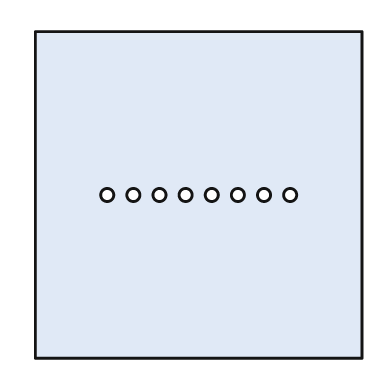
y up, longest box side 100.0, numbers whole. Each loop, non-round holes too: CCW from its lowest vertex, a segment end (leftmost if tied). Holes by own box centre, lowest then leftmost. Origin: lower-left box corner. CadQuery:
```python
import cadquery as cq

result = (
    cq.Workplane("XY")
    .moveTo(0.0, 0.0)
    .lineTo(100.0, 0.0)
    .lineTo(100.0, 100.0)
    .lineTo(0.0, 100.0)
    .close()
    .moveTo(22.0, 50.0)
    .circle(2.0)
    .moveTo(30.0, 50.0)
    .circle(2.0)
    .moveTo(38.0, 50.0)
    .circle(2.0)
    .moveTo(46.0, 50.0)
    .circle(2.0)
    .moveTo(54.0, 50.0)
    .circle(2.0)
    .moveTo(62.0, 50.0)
    .circle(2.0)
    .moveTo(70.0, 50.0)
    .circle(2.0)
    .moveTo(78.0, 50.0)
    .circle(2.0)
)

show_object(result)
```